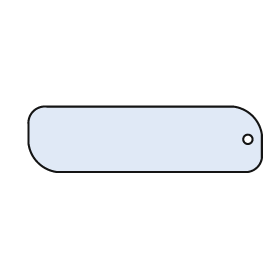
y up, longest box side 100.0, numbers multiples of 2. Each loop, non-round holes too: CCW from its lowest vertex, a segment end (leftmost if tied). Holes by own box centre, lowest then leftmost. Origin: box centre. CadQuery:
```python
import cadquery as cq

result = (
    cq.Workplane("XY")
    .moveTo(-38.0, -14.0)
    .lineTo(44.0, -14.0)
    .threePointArc((48.0, -12.0), (50.0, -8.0))
    .lineTo(50.0, 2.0)
    .threePointArc((46.0, 10.0), (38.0, 14.0))
    .lineTo(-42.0, 14.0)
    .threePointArc((-48.0, 12.0), (-50.0, 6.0))
    .lineTo(-50.0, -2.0)
    .threePointArc((-46.0, -10.0), (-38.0, -14.0))
    .close()
    .moveTo(44.0, 0.0)
    .circle(2.0)
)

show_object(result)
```